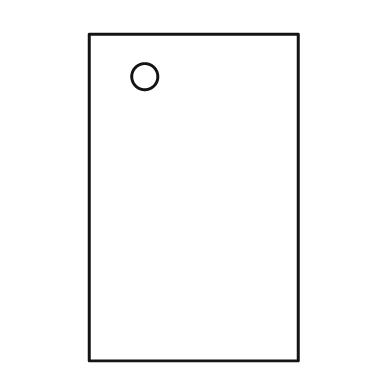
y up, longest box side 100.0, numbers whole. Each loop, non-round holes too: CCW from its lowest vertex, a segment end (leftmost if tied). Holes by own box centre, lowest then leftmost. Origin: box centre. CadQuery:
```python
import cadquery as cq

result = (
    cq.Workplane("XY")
    .moveTo(-32.0, -50.0)
    .lineTo(32.0, -50.0)
    .lineTo(32.0, 50.0)
    .lineTo(-32.0, 50.0)
    .close()
    .moveTo(-15.0, 37.0)
    .circle(4.0)
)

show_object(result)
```